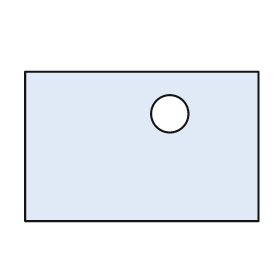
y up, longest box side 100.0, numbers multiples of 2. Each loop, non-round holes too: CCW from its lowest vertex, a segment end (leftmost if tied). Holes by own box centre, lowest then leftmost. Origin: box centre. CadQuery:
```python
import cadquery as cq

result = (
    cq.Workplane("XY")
    .moveTo(-50.0, -32.0)
    .lineTo(50.0, -32.0)
    .lineTo(50.0, 32.0)
    .lineTo(-50.0, 32.0)
    .close()
    .moveTo(12.0, 14.0)
    .circle(8.0)
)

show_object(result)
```